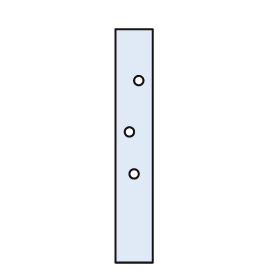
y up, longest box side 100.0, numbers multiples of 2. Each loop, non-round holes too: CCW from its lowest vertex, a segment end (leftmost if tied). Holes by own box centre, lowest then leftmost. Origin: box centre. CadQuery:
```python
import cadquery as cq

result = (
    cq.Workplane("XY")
    .moveTo(-8.0, -50.0)
    .lineTo(8.0, -50.0)
    .lineTo(8.0, 50.0)
    .lineTo(-8.0, 50.0)
    .close()
    .moveTo(0.0, -12.0)
    .circle(2.0)
    .moveTo(-2.0, 6.0)
    .circle(2.0)
    .moveTo(2.0, 28.0)
    .circle(2.0)
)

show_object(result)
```